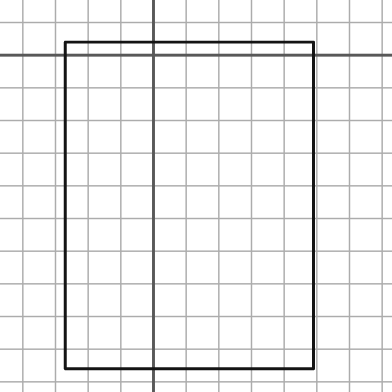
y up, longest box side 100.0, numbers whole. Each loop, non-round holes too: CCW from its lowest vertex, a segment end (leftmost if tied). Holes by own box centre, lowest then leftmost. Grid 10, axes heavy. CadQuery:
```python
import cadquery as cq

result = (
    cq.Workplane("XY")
    .moveTo(-27.0, -96.0)
    .lineTo(49.0, -96.0)
    .lineTo(49.0, 4.0)
    .lineTo(-27.0, 4.0)
    .close()
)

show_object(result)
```